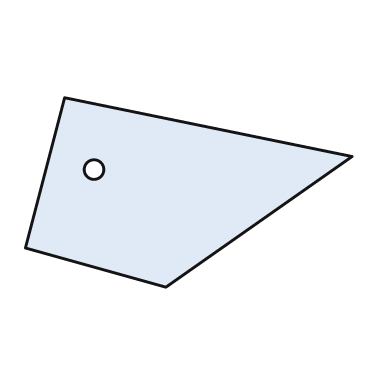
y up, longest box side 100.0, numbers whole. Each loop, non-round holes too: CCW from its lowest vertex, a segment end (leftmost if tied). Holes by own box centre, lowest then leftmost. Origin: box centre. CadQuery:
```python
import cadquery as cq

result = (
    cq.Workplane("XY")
    .moveTo(-7.0, -29.0)
    .lineTo(50.0, 11.0)
    .lineTo(-38.0, 29.0)
    .lineTo(-50.0, -17.0)
    .close()
    .moveTo(-29.0, 7.0)
    .circle(3.0)
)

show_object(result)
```